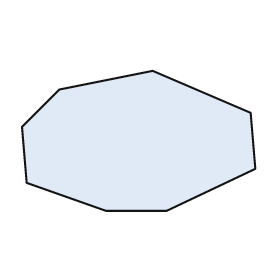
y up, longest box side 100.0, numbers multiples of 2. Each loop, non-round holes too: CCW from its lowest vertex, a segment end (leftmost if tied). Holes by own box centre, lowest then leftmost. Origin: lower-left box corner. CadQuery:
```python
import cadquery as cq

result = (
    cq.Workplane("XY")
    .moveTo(36.0, 0.0)
    .lineTo(62.0, 0.0)
    .lineTo(100.0, 18.0)
    .lineTo(98.0, 42.0)
    .lineTo(56.0, 60.0)
    .lineTo(16.0, 52.0)
    .lineTo(0.0, 36.0)
    .lineTo(2.0, 12.0)
    .close()
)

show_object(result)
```